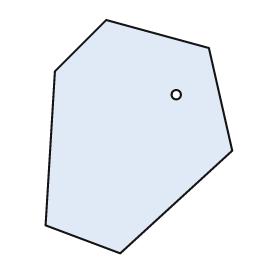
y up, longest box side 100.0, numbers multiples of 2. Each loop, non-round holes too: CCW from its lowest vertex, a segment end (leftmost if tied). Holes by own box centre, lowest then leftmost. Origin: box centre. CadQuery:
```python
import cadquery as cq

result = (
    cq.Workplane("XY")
    .moveTo(-8.0, -50.0)
    .lineTo(40.0, -6.0)
    .lineTo(30.0, 38.0)
    .lineTo(-14.0, 50.0)
    .lineTo(-36.0, 28.0)
    .lineTo(-40.0, -38.0)
    .close()
    .moveTo(16.0, 18.0)
    .circle(2.0)
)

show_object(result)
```